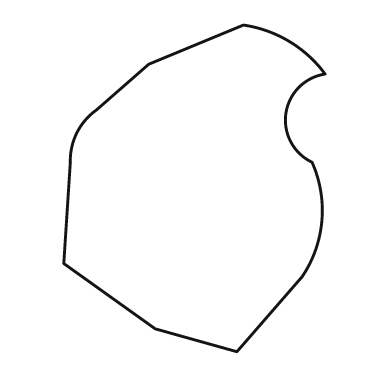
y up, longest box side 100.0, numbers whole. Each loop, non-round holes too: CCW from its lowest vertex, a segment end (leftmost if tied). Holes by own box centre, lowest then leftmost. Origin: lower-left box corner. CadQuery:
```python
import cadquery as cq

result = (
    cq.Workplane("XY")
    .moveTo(53.0, 0.0)
    .lineTo(73.0, 23.0)
    .threePointArc((79.0, 40.0), (76.0, 58.0))
    .threePointArc((68.0, 73.0), (80.0, 85.0))
    .threePointArc((69.0, 95.0), (55.0, 100.0))
    .lineTo(26.0, 88.0)
    .lineTo(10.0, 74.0)
    .threePointArc((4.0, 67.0), (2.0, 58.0))
    .lineTo(0.0, 27.0)
    .lineTo(28.0, 7.0)
    .close()
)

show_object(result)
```